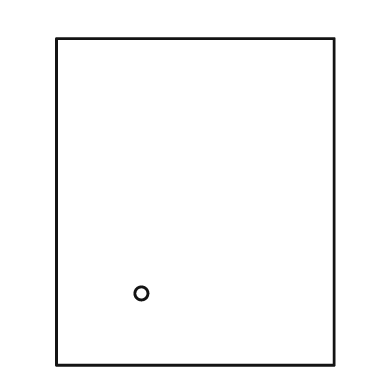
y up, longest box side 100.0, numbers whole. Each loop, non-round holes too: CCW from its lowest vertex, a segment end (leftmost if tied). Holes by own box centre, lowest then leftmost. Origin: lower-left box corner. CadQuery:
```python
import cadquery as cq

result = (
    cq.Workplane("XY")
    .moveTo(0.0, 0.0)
    .lineTo(85.0, 0.0)
    .lineTo(85.0, 100.0)
    .lineTo(0.0, 100.0)
    .close()
    .moveTo(26.0, 22.0)
    .circle(2.0)
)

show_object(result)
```